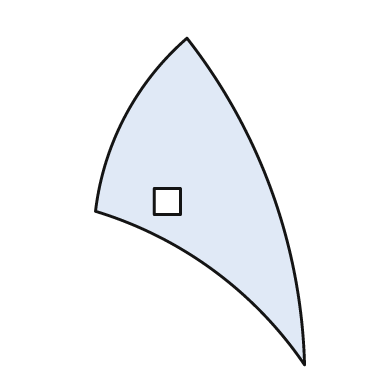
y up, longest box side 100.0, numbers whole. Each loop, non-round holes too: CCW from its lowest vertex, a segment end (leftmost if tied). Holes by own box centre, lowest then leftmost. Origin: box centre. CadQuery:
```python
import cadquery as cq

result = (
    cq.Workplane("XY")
    .moveTo(32.0, -50.0)
    .threePointArc((22.0, 3.0), (-4.0, 50.0))
    .threePointArc((-23.0, 26.0), (-32.0, -3.0))
    .threePointArc((4.0, -21.0), (32.0, -50.0))
    .close()
    .moveTo(-14.0, -4.0)
    .lineTo(-6.0, -4.0)
    .lineTo(-6.0, 4.0)
    .lineTo(-14.0, 4.0)
    .close()
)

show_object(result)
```